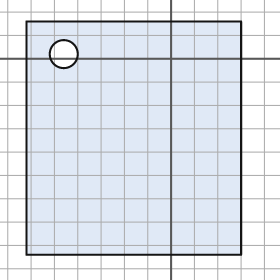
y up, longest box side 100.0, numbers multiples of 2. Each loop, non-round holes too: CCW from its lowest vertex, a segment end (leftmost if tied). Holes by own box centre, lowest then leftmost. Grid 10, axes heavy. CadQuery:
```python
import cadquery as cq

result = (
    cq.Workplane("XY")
    .moveTo(-62.0, -84.0)
    .lineTo(30.0, -84.0)
    .lineTo(30.0, 16.0)
    .lineTo(-62.0, 16.0)
    .close()
    .moveTo(-46.0, 2.0)
    .circle(6.0)
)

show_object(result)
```